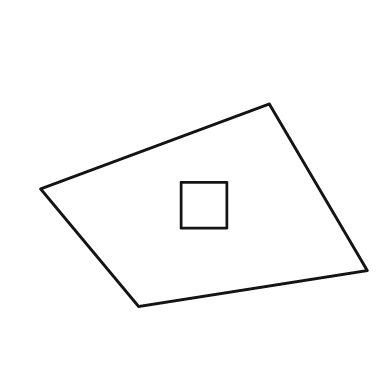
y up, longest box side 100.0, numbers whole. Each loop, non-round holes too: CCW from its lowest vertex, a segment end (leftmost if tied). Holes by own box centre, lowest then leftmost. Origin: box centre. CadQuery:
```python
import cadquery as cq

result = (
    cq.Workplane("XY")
    .moveTo(-20.0, -31.0)
    .lineTo(50.0, -20.0)
    .lineTo(20.0, 31.0)
    .lineTo(-50.0, 5.0)
    .close()
    .moveTo(-7.0, -7.0)
    .lineTo(7.0, -7.0)
    .lineTo(7.0, 7.0)
    .lineTo(-7.0, 7.0)
    .close()
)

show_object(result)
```